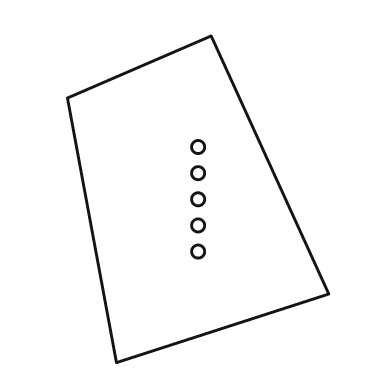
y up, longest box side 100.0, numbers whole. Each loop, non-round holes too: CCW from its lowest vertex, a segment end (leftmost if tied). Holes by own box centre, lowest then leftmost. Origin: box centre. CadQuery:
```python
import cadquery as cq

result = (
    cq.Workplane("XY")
    .moveTo(-25.0, -50.0)
    .lineTo(40.0, -29.0)
    .lineTo(4.0, 50.0)
    .lineTo(-40.0, 31.0)
    .close()
    .moveTo(0.0, -16.0)
    .circle(2.0)
    .moveTo(0.0, -8.0)
    .circle(2.0)
    .moveTo(0.0, 0.0)
    .circle(2.0)
    .moveTo(0.0, 8.0)
    .circle(2.0)
    .moveTo(0.0, 16.0)
    .circle(2.0)
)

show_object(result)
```